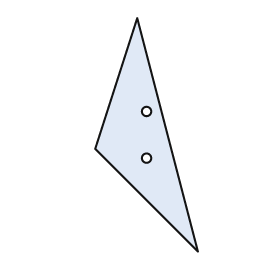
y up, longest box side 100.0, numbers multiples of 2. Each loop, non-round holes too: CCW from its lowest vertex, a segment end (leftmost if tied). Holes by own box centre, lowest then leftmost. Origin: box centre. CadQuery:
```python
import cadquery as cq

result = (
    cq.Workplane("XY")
    .moveTo(22.0, -50.0)
    .lineTo(-4.0, 50.0)
    .lineTo(-22.0, -6.0)
    .close()
    .moveTo(0.0, -10.0)
    .circle(2.0)
    .moveTo(0.0, 10.0)
    .circle(2.0)
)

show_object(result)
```